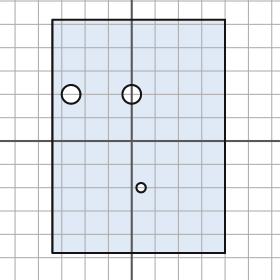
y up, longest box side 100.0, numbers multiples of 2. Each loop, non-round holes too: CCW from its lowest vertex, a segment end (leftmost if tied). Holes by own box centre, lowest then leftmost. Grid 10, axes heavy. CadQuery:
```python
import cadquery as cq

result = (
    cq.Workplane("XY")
    .moveTo(-34.0, -48.0)
    .lineTo(40.0, -48.0)
    .lineTo(40.0, 52.0)
    .lineTo(-34.0, 52.0)
    .close()
    .moveTo(4.0, -20.0)
    .circle(2.0)
    .moveTo(-26.0, 20.0)
    .circle(4.0)
    .moveTo(0.0, 20.0)
    .circle(4.0)
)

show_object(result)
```